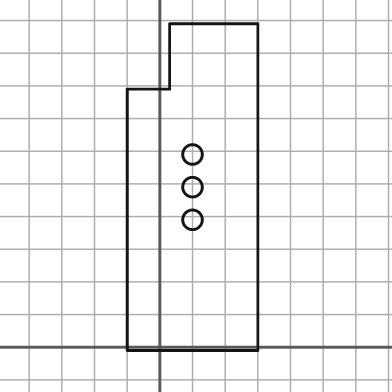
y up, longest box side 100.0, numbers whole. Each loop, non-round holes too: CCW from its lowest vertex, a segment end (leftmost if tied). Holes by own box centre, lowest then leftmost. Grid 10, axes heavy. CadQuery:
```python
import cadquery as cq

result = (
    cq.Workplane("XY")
    .moveTo(-10.0, -1.0)
    .lineTo(30.0, -1.0)
    .lineTo(30.0, 99.0)
    .lineTo(3.0, 99.0)
    .lineTo(3.0, 79.0)
    .lineTo(-10.0, 79.0)
    .close()
    .moveTo(10.0, 39.0)
    .circle(3.0)
    .moveTo(10.0, 49.0)
    .circle(3.0)
    .moveTo(10.0, 59.0)
    .circle(3.0)
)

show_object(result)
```